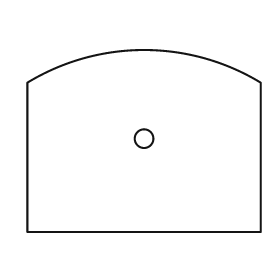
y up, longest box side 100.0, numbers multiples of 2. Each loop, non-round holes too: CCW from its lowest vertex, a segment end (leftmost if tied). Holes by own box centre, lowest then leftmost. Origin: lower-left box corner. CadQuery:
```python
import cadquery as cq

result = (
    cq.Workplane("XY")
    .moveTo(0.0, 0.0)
    .lineTo(100.0, 0.0)
    .lineTo(100.0, 64.0)
    .threePointArc((50.0, 78.0), (0.0, 64.0))
    .close()
    .moveTo(50.0, 40.0)
    .circle(4.0)
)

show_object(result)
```